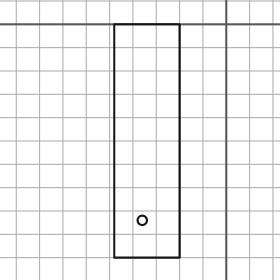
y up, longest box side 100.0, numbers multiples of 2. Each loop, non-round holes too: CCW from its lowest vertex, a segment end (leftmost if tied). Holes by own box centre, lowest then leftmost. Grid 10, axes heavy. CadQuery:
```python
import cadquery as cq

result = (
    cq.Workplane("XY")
    .moveTo(-48.0, -100.0)
    .lineTo(-20.0, -100.0)
    .lineTo(-20.0, 0.0)
    .lineTo(-48.0, 0.0)
    .close()
    .moveTo(-36.0, -84.0)
    .circle(2.0)
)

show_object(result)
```